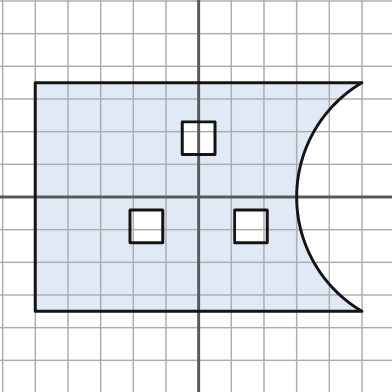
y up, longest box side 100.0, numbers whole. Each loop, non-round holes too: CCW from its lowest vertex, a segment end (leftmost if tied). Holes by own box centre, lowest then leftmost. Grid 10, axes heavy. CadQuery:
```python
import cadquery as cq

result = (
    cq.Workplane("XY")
    .moveTo(-50.0, -35.0)
    .lineTo(50.0, -35.0)
    .threePointArc((30.0, 0.0), (50.0, 35.0))
    .lineTo(-50.0, 35.0)
    .close()
    .moveTo(-21.0, -14.0)
    .lineTo(-11.0, -14.0)
    .lineTo(-11.0, -4.0)
    .lineTo(-21.0, -4.0)
    .close()
    .moveTo(11.0, -14.0)
    .lineTo(21.0, -14.0)
    .lineTo(21.0, -4.0)
    .lineTo(11.0, -4.0)
    .close()
    .moveTo(-5.0, 13.0)
    .lineTo(5.0, 13.0)
    .lineTo(5.0, 23.0)
    .lineTo(-5.0, 23.0)
    .close()
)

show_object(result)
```